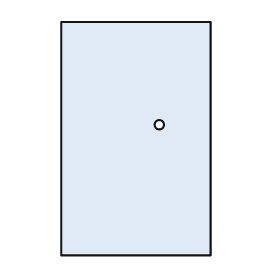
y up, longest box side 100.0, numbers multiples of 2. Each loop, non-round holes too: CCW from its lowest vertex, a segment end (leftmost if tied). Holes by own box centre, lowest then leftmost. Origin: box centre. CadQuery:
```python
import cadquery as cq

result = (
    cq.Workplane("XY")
    .moveTo(-32.0, -50.0)
    .lineTo(32.0, -50.0)
    .lineTo(32.0, 50.0)
    .lineTo(-32.0, 50.0)
    .close()
    .moveTo(10.0, 6.0)
    .circle(2.0)
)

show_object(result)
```